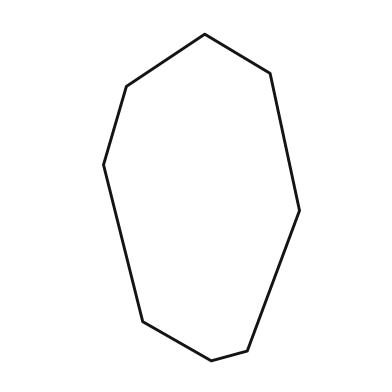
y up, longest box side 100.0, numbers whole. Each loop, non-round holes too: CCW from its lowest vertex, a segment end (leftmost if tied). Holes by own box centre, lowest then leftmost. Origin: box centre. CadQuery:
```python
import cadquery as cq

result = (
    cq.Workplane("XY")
    .moveTo(3.0, -50.0)
    .lineTo(14.0, -47.0)
    .lineTo(30.0, -4.0)
    .lineTo(21.0, 38.0)
    .lineTo(1.0, 50.0)
    .lineTo(-23.0, 34.0)
    .lineTo(-30.0, 10.0)
    .lineTo(-18.0, -38.0)
    .close()
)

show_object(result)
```